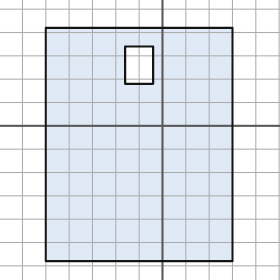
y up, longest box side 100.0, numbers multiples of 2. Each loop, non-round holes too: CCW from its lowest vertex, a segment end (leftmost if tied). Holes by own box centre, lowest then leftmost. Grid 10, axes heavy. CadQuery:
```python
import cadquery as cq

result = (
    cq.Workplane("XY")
    .moveTo(-50.0, -58.0)
    .lineTo(30.0, -58.0)
    .lineTo(30.0, 42.0)
    .lineTo(-50.0, 42.0)
    .close()
    .moveTo(-16.0, 18.0)
    .lineTo(-4.0, 18.0)
    .lineTo(-4.0, 34.0)
    .lineTo(-16.0, 34.0)
    .close()
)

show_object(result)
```